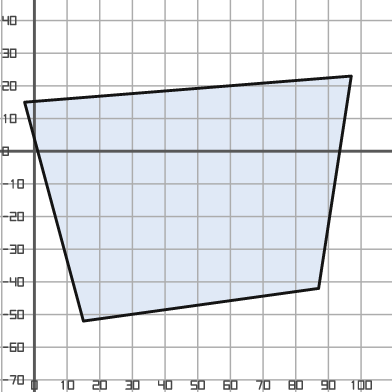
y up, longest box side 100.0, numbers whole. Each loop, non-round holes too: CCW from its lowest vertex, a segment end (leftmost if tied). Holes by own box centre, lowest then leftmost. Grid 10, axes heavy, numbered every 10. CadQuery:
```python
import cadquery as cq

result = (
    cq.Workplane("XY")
    .moveTo(15.0, -52.0)
    .lineTo(87.0, -42.0)
    .lineTo(97.0, 23.0)
    .lineTo(-3.0, 15.0)
    .close()
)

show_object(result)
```